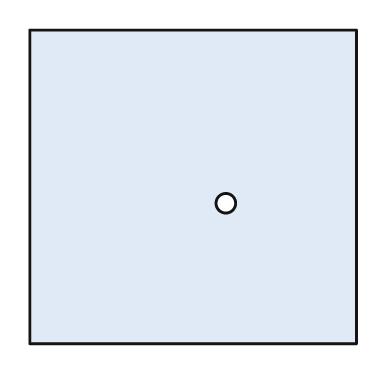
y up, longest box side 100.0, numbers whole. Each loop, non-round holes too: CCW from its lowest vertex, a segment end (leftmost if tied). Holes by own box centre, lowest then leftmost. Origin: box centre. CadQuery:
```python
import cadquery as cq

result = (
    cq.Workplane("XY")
    .moveTo(-50.0, -48.0)
    .lineTo(50.0, -48.0)
    .lineTo(50.0, 48.0)
    .lineTo(-50.0, 48.0)
    .close()
    .moveTo(10.0, -5.0)
    .circle(3.0)
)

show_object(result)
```